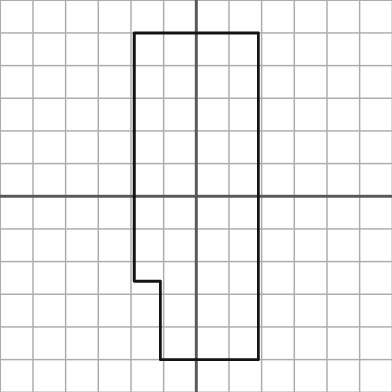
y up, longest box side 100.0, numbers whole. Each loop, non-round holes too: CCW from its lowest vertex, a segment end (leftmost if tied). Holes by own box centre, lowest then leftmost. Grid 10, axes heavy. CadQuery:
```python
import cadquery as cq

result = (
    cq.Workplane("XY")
    .moveTo(-11.0, -50.0)
    .lineTo(19.0, -50.0)
    .lineTo(19.0, 50.0)
    .lineTo(-19.0, 50.0)
    .lineTo(-19.0, -26.0)
    .lineTo(-11.0, -26.0)
    .close()
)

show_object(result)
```